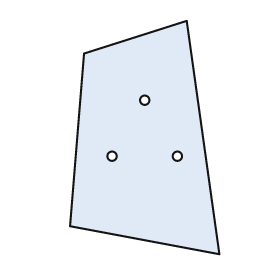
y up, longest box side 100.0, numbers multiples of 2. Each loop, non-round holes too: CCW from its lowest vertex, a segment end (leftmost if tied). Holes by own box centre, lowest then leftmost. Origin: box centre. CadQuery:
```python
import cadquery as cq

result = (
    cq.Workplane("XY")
    .moveTo(32.0, -50.0)
    .lineTo(18.0, 50.0)
    .lineTo(-26.0, 36.0)
    .lineTo(-32.0, -38.0)
    .close()
    .moveTo(-14.0, -8.0)
    .circle(2.0)
    .moveTo(14.0, -8.0)
    .circle(2.0)
    .moveTo(0.0, 16.0)
    .circle(2.0)
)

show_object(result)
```